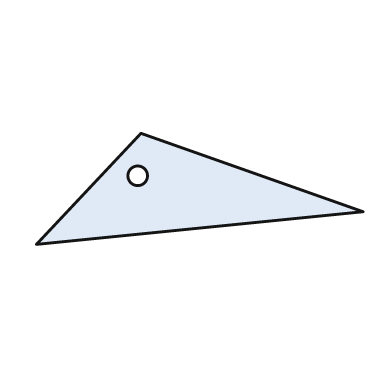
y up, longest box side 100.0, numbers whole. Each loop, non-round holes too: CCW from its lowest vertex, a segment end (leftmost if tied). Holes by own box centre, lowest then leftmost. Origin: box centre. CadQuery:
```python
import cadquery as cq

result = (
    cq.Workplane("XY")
    .moveTo(-50.0, -17.0)
    .lineTo(50.0, -7.0)
    .lineTo(-18.0, 17.0)
    .close()
    .moveTo(-19.0, 4.0)
    .circle(3.0)
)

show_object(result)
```